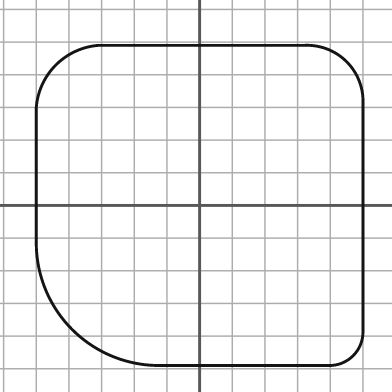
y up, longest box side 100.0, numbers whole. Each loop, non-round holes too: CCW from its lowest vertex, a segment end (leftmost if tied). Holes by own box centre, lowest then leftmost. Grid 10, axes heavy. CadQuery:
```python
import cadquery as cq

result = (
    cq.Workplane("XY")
    .moveTo(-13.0, -49.0)
    .lineTo(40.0, -49.0)
    .threePointArc((47.0, -46.0), (50.0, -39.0))
    .lineTo(50.0, 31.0)
    .threePointArc((45.0, 44.0), (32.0, 49.0))
    .lineTo(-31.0, 49.0)
    .threePointArc((-44.0, 43.0), (-50.0, 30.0))
    .lineTo(-50.0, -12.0)
    .threePointArc((-39.0, -38.0), (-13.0, -49.0))
    .close()
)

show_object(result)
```